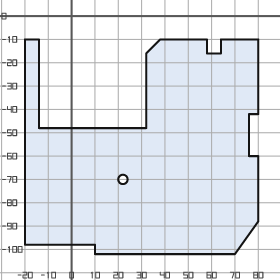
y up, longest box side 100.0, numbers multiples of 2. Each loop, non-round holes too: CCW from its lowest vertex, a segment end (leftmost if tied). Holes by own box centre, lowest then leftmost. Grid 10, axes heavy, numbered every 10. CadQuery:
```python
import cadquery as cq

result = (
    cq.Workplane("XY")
    .moveTo(10.0, -102.0)
    .lineTo(70.0, -102.0)
    .lineTo(80.0, -88.0)
    .lineTo(80.0, -60.0)
    .lineTo(76.0, -60.0)
    .lineTo(76.0, -42.0)
    .lineTo(80.0, -42.0)
    .lineTo(80.0, -10.0)
    .lineTo(64.0, -10.0)
    .lineTo(64.0, -16.0)
    .lineTo(58.0, -16.0)
    .lineTo(58.0, -10.0)
    .lineTo(38.0, -10.0)
    .lineTo(32.0, -16.0)
    .lineTo(32.0, -48.0)
    .lineTo(-14.0, -48.0)
    .lineTo(-14.0, -10.0)
    .lineTo(-20.0, -10.0)
    .lineTo(-20.0, -98.0)
    .lineTo(10.0, -98.0)
    .close()
    .moveTo(22.0, -70.0)
    .circle(2.0)
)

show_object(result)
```